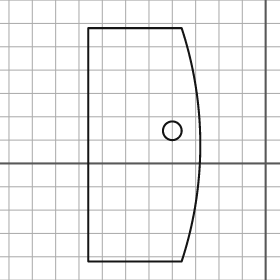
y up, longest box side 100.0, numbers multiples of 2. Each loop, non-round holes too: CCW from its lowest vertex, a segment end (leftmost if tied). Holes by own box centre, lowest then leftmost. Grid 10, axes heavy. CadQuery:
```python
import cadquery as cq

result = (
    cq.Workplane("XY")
    .moveTo(-76.0, -42.0)
    .lineTo(-36.0, -42.0)
    .threePointArc((-28.0, 8.0), (-36.0, 58.0))
    .lineTo(-76.0, 58.0)
    .close()
    .moveTo(-40.0, 14.0)
    .circle(4.0)
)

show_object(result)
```